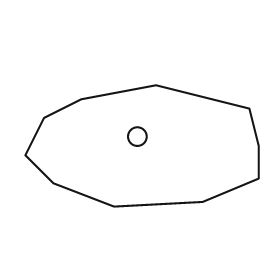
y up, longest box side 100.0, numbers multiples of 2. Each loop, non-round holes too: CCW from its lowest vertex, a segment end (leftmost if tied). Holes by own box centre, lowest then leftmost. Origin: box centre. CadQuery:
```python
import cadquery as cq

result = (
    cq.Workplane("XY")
    .moveTo(-12.0, -26.0)
    .lineTo(26.0, -24.0)
    .lineTo(50.0, -14.0)
    .lineTo(50.0, 0.0)
    .lineTo(46.0, 16.0)
    .lineTo(6.0, 26.0)
    .lineTo(-26.0, 20.0)
    .lineTo(-42.0, 12.0)
    .lineTo(-50.0, -4.0)
    .lineTo(-38.0, -16.0)
    .close()
    .moveTo(-2.0, 4.0)
    .circle(4.0)
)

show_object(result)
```